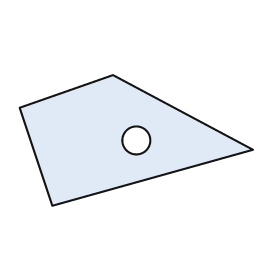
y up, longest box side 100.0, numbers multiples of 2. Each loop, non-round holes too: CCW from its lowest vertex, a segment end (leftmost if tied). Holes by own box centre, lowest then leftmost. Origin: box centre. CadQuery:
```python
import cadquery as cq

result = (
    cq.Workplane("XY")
    .moveTo(-36.0, -28.0)
    .lineTo(50.0, -4.0)
    .lineTo(-10.0, 28.0)
    .lineTo(-50.0, 14.0)
    .close()
    .moveTo(0.0, 0.0)
    .circle(6.0)
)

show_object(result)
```